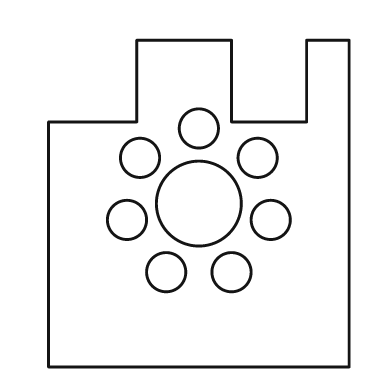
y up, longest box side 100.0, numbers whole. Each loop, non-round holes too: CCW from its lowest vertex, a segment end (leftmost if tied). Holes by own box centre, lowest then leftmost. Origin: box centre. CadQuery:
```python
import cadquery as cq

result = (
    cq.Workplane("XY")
    .moveTo(-46.0, -50.0)
    .lineTo(46.0, -50.0)
    .lineTo(46.0, 50.0)
    .lineTo(33.0, 50.0)
    .lineTo(33.0, 25.0)
    .lineTo(10.0, 25.0)
    .lineTo(10.0, 50.0)
    .lineTo(-19.0, 50.0)
    .lineTo(-19.0, 25.0)
    .lineTo(-46.0, 25.0)
    .close()
    .moveTo(-10.0, -21.0)
    .circle(6.0)
    .moveTo(10.0, -21.0)
    .circle(6.0)
    .moveTo(-22.0, -5.0)
    .circle(6.0)
    .moveTo(22.0, -5.0)
    .circle(6.0)
    .moveTo(0.0, 0.0)
    .circle(13.0)
    .moveTo(-18.0, 14.0)
    .circle(6.0)
    .moveTo(18.0, 14.0)
    .circle(6.0)
    .moveTo(0.0, 23.0)
    .circle(6.0)
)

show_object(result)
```